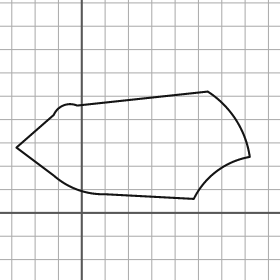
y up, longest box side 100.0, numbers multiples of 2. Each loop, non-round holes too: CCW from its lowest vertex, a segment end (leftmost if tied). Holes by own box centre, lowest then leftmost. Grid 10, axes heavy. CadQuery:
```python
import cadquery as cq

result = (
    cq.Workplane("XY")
    .moveTo(48.0, 6.0)
    .threePointArc((58.0, 18.0), (72.0, 24.0))
    .threePointArc((66.0, 40.0), (54.0, 52.0))
    .lineTo(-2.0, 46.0)
    .threePointArc((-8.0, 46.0), (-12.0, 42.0))
    .lineTo(-28.0, 28.0)
    .lineTo(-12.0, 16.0)
    .threePointArc((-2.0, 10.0), (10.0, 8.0))
    .close()
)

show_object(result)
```